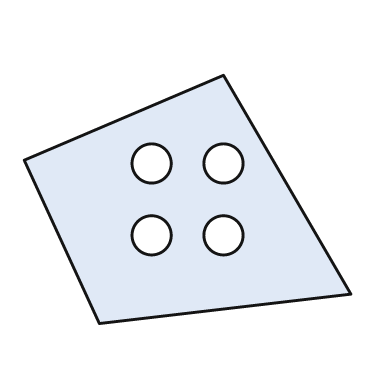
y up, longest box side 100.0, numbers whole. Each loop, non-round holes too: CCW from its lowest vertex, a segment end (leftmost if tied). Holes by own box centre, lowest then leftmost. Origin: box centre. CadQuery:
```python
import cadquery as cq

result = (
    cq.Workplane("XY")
    .moveTo(-27.0, -38.0)
    .lineTo(50.0, -29.0)
    .lineTo(11.0, 38.0)
    .lineTo(-50.0, 12.0)
    .close()
    .moveTo(-11.0, -11.0)
    .circle(6.0)
    .moveTo(11.0, -11.0)
    .circle(6.0)
    .moveTo(-11.0, 11.0)
    .circle(6.0)
    .moveTo(11.0, 11.0)
    .circle(6.0)
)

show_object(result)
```